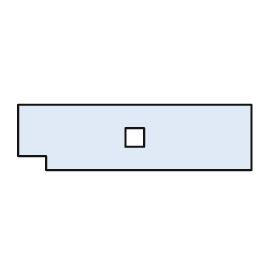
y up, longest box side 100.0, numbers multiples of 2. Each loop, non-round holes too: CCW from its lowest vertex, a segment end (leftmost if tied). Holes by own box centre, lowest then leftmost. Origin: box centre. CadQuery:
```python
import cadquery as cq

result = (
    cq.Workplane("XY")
    .moveTo(-38.0, -14.0)
    .lineTo(50.0, -14.0)
    .lineTo(50.0, 14.0)
    .lineTo(-50.0, 14.0)
    .lineTo(-50.0, -8.0)
    .lineTo(-38.0, -8.0)
    .close()
    .moveTo(-4.0, -4.0)
    .lineTo(4.0, -4.0)
    .lineTo(4.0, 4.0)
    .lineTo(-4.0, 4.0)
    .close()
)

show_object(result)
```